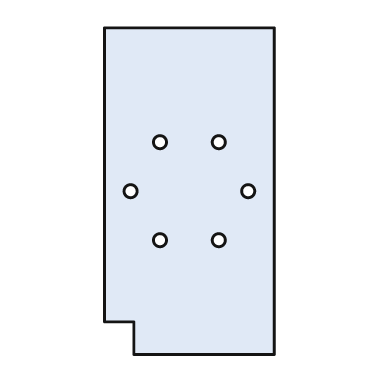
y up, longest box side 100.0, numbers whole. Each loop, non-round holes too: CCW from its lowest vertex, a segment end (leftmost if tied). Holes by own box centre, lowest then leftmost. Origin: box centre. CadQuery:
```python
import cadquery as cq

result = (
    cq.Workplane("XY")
    .moveTo(-17.0, -50.0)
    .lineTo(26.0, -50.0)
    .lineTo(26.0, 50.0)
    .lineTo(-26.0, 50.0)
    .lineTo(-26.0, -40.0)
    .lineTo(-17.0, -40.0)
    .close()
    .moveTo(-9.0, -15.0)
    .circle(2.0)
    .moveTo(9.0, -15.0)
    .circle(2.0)
    .moveTo(-18.0, 0.0)
    .circle(2.0)
    .moveTo(18.0, 0.0)
    .circle(2.0)
    .moveTo(-9.0, 15.0)
    .circle(2.0)
    .moveTo(9.0, 15.0)
    .circle(2.0)
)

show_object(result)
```